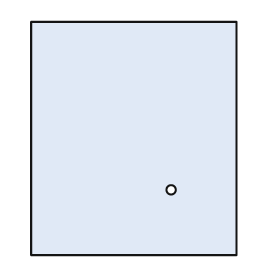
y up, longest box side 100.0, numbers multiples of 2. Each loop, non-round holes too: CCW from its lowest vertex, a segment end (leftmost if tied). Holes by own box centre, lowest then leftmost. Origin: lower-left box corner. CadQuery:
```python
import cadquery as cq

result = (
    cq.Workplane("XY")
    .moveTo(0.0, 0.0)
    .lineTo(88.0, 0.0)
    .lineTo(88.0, 100.0)
    .lineTo(0.0, 100.0)
    .close()
    .moveTo(60.0, 28.0)
    .circle(2.0)
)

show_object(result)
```